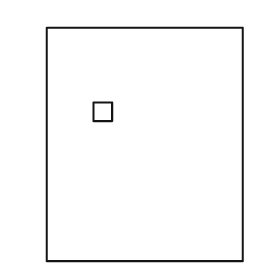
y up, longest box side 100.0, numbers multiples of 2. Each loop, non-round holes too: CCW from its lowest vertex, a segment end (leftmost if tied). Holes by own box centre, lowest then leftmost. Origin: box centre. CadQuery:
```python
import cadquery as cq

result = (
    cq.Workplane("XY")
    .moveTo(-42.0, -50.0)
    .lineTo(42.0, -50.0)
    .lineTo(42.0, 50.0)
    .lineTo(-42.0, 50.0)
    .close()
    .moveTo(-22.0, 10.0)
    .lineTo(-14.0, 10.0)
    .lineTo(-14.0, 18.0)
    .lineTo(-22.0, 18.0)
    .close()
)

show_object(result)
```